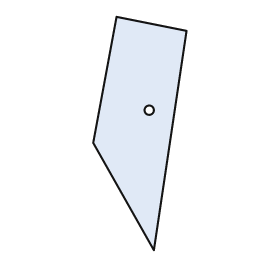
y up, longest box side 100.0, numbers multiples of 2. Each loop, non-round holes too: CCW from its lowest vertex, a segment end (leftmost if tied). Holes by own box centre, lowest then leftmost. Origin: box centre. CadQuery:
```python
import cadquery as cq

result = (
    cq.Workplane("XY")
    .moveTo(6.0, -50.0)
    .lineTo(20.0, 44.0)
    .lineTo(-10.0, 50.0)
    .lineTo(-20.0, -4.0)
    .close()
    .moveTo(4.0, 10.0)
    .circle(2.0)
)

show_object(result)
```